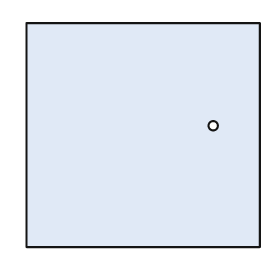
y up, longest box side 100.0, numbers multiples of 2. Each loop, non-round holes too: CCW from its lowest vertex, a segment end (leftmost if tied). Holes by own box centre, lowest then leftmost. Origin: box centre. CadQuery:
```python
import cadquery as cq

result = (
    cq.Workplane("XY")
    .moveTo(-50.0, -48.0)
    .lineTo(50.0, -48.0)
    .lineTo(50.0, 48.0)
    .lineTo(-50.0, 48.0)
    .close()
    .moveTo(30.0, 4.0)
    .circle(2.0)
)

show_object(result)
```